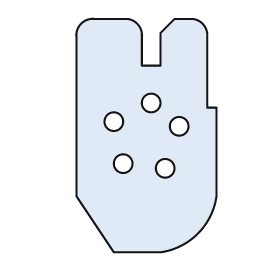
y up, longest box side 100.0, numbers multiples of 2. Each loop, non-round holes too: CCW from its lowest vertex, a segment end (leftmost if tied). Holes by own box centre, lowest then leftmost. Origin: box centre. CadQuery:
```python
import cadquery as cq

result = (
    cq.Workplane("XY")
    .moveTo(-14.0, -50.0)
    .lineTo(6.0, -50.0)
    .threePointArc((22.0, -42.0), (30.0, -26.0))
    .lineTo(30.0, 12.0)
    .lineTo(26.0, 12.0)
    .lineTo(26.0, 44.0)
    .threePointArc((24.0, 48.0), (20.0, 50.0))
    .lineTo(12.0, 50.0)
    .lineTo(6.0, 44.0)
    .lineTo(6.0, 30.0)
    .lineTo(-2.0, 30.0)
    .lineTo(-2.0, 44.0)
    .threePointArc((-4.0, 48.0), (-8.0, 50.0))
    .lineTo(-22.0, 50.0)
    .threePointArc((-28.0, 48.0), (-30.0, 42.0))
    .lineTo(-30.0, -26.0)
    .close()
    .moveTo(8.0, -14.0)
    .circle(4.0)
    .moveTo(-10.0, -12.0)
    .circle(4.0)
    .moveTo(14.0, 4.0)
    .circle(4.0)
    .moveTo(-14.0, 6.0)
    .circle(4.0)
    .moveTo(2.0, 14.0)
    .circle(4.0)
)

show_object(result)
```